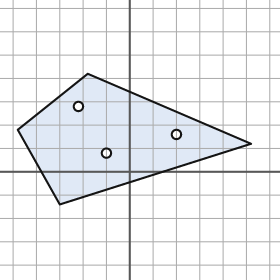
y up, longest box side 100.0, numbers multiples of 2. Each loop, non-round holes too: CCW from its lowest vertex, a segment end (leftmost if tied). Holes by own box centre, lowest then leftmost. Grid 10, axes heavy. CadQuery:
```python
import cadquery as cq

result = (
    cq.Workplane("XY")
    .moveTo(-30.0, -14.0)
    .lineTo(52.0, 12.0)
    .lineTo(-18.0, 42.0)
    .lineTo(-48.0, 18.0)
    .close()
    .moveTo(-10.0, 8.0)
    .circle(2.0)
    .moveTo(20.0, 16.0)
    .circle(2.0)
    .moveTo(-22.0, 28.0)
    .circle(2.0)
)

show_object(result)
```